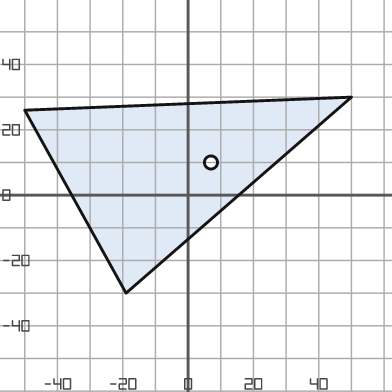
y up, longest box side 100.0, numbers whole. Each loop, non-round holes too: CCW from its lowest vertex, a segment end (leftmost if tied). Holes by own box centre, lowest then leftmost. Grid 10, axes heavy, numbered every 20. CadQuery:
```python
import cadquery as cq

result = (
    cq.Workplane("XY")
    .moveTo(-19.0, -30.0)
    .lineTo(50.0, 30.0)
    .lineTo(-50.0, 26.0)
    .close()
    .moveTo(7.0, 10.0)
    .circle(2.0)
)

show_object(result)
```